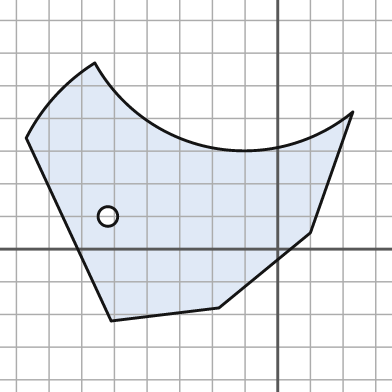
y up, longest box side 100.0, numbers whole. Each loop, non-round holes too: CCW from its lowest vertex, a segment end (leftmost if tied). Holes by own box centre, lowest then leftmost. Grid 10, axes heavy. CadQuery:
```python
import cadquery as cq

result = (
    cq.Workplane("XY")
    .moveTo(-51.0, -22.0)
    .lineTo(-18.0, -18.0)
    .lineTo(10.0, 5.0)
    .lineTo(23.0, 42.0)
    .threePointArc((-20.0, 31.0), (-56.0, 57.0))
    .threePointArc((-68.0, 47.0), (-77.0, 34.0))
    .close()
    .moveTo(-52.0, 10.0)
    .circle(3.0)
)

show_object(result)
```